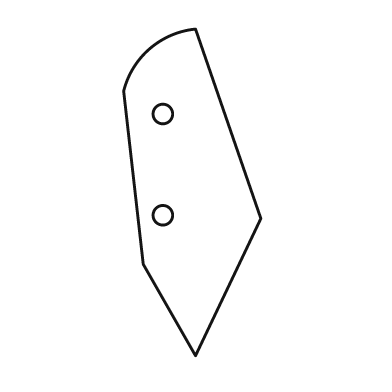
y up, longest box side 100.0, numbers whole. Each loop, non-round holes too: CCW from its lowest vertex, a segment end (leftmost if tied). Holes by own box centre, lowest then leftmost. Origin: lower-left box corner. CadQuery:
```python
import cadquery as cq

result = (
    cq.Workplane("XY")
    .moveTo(22.0, 0.0)
    .lineTo(42.0, 42.0)
    .lineTo(22.0, 100.0)
    .threePointArc((8.0, 94.0), (0.0, 81.0))
    .lineTo(6.0, 28.0)
    .close()
    .moveTo(12.0, 43.0)
    .circle(3.0)
    .moveTo(12.0, 74.0)
    .circle(3.0)
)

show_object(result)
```